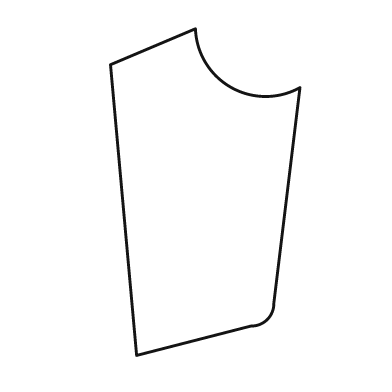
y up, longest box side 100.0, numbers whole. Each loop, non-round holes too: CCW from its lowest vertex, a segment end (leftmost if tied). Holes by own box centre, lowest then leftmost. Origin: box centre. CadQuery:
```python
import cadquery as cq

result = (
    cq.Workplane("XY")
    .moveTo(-21.0, -50.0)
    .lineTo(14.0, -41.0)
    .threePointArc((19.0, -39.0), (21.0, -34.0))
    .lineTo(29.0, 32.0)
    .threePointArc((8.0, 32.0), (-3.0, 50.0))
    .lineTo(-29.0, 39.0)
    .close()
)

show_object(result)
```